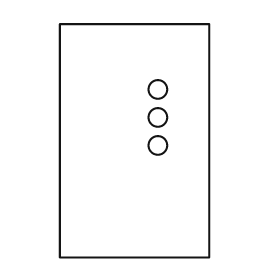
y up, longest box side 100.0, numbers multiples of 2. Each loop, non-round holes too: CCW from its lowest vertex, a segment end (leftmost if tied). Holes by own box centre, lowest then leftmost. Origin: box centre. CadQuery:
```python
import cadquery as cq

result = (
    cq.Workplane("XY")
    .moveTo(-32.0, -50.0)
    .lineTo(32.0, -50.0)
    .lineTo(32.0, 50.0)
    .lineTo(-32.0, 50.0)
    .close()
    .moveTo(10.0, -2.0)
    .circle(4.0)
    .moveTo(10.0, 10.0)
    .circle(4.0)
    .moveTo(10.0, 22.0)
    .circle(4.0)
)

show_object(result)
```